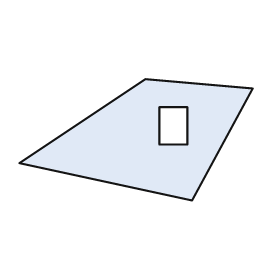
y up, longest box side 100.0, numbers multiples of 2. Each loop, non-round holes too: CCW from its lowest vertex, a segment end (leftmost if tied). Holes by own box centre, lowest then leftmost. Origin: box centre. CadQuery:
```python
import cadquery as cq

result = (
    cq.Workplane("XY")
    .moveTo(24.0, -26.0)
    .lineTo(50.0, 22.0)
    .lineTo(4.0, 26.0)
    .lineTo(-50.0, -10.0)
    .close()
    .moveTo(10.0, -2.0)
    .lineTo(22.0, -2.0)
    .lineTo(22.0, 14.0)
    .lineTo(10.0, 14.0)
    .close()
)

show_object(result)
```